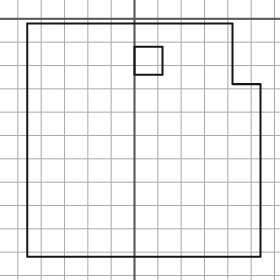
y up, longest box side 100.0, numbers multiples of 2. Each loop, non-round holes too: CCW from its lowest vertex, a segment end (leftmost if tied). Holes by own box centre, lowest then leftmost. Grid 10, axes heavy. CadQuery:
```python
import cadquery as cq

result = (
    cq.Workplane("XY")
    .moveTo(-46.0, -102.0)
    .lineTo(54.0, -102.0)
    .lineTo(54.0, -28.0)
    .lineTo(42.0, -28.0)
    .lineTo(42.0, -2.0)
    .lineTo(-46.0, -2.0)
    .close()
    .moveTo(0.0, -24.0)
    .lineTo(12.0, -24.0)
    .lineTo(12.0, -12.0)
    .lineTo(0.0, -12.0)
    .close()
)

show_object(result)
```